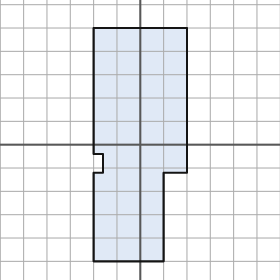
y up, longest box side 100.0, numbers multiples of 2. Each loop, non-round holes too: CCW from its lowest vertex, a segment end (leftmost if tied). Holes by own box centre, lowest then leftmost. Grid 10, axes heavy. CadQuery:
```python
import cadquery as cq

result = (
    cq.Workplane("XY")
    .moveTo(-20.0, -50.0)
    .lineTo(10.0, -50.0)
    .lineTo(10.0, -12.0)
    .lineTo(20.0, -12.0)
    .lineTo(20.0, 50.0)
    .lineTo(-20.0, 50.0)
    .lineTo(-20.0, -4.0)
    .lineTo(-16.0, -4.0)
    .lineTo(-16.0, -12.0)
    .lineTo(-20.0, -12.0)
    .close()
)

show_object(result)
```